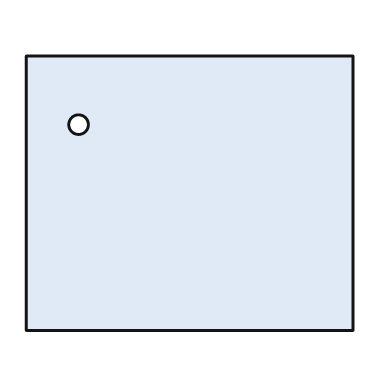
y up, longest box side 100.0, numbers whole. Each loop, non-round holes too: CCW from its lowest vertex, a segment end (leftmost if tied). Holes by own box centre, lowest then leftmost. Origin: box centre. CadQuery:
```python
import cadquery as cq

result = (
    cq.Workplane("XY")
    .moveTo(-50.0, -42.0)
    .lineTo(50.0, -42.0)
    .lineTo(50.0, 42.0)
    .lineTo(-50.0, 42.0)
    .close()
    .moveTo(-34.0, 21.0)
    .circle(3.0)
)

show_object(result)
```